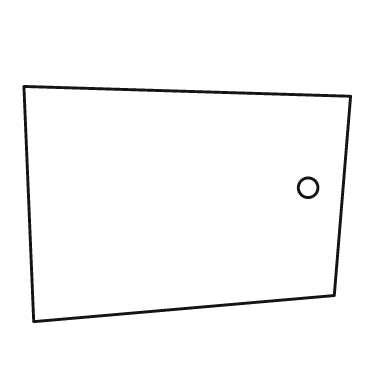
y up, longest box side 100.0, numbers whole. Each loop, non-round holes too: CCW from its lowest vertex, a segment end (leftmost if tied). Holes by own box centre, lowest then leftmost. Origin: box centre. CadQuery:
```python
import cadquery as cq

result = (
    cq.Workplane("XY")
    .moveTo(-47.0, -36.0)
    .lineTo(45.0, -28.0)
    .lineTo(50.0, 33.0)
    .lineTo(-50.0, 36.0)
    .close()
    .moveTo(37.0, 5.0)
    .circle(3.0)
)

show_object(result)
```